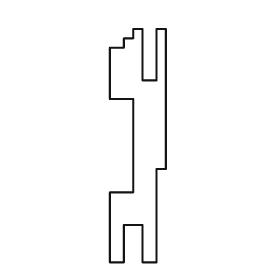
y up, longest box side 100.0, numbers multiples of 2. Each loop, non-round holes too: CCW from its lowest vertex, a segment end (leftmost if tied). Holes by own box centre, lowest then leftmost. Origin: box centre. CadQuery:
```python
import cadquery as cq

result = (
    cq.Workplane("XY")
    .moveTo(-12.0, -50.0)
    .lineTo(-6.0, -50.0)
    .lineTo(-6.0, -34.0)
    .lineTo(2.0, -34.0)
    .lineTo(2.0, -50.0)
    .lineTo(8.0, -50.0)
    .lineTo(8.0, -10.0)
    .lineTo(12.0, -10.0)
    .lineTo(12.0, 50.0)
    .lineTo(8.0, 50.0)
    .lineTo(8.0, 28.0)
    .lineTo(2.0, 28.0)
    .lineTo(2.0, 50.0)
    .lineTo(-2.0, 50.0)
    .lineTo(-2.0, 46.0)
    .lineTo(-6.0, 46.0)
    .lineTo(-6.0, 42.0)
    .lineTo(-12.0, 42.0)
    .lineTo(-12.0, 20.0)
    .lineTo(-2.0, 20.0)
    .lineTo(-2.0, -20.0)
    .lineTo(-12.0, -20.0)
    .close()
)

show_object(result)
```